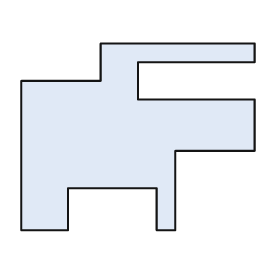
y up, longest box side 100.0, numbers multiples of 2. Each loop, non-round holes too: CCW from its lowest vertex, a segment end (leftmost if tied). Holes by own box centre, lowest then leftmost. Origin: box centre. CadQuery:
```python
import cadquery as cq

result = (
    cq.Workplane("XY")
    .moveTo(-50.0, -40.0)
    .lineTo(-30.0, -40.0)
    .lineTo(-30.0, -22.0)
    .lineTo(8.0, -22.0)
    .lineTo(8.0, -40.0)
    .lineTo(16.0, -40.0)
    .lineTo(16.0, -6.0)
    .lineTo(50.0, -6.0)
    .lineTo(50.0, 16.0)
    .lineTo(0.0, 16.0)
    .lineTo(0.0, 32.0)
    .lineTo(50.0, 32.0)
    .lineTo(50.0, 40.0)
    .lineTo(-16.0, 40.0)
    .lineTo(-16.0, 24.0)
    .lineTo(-50.0, 24.0)
    .close()
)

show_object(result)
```